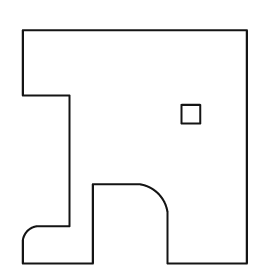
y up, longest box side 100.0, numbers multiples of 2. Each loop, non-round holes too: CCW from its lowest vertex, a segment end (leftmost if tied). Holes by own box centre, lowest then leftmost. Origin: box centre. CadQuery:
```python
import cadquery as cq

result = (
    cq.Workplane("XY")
    .moveTo(-48.0, -50.0)
    .lineTo(-18.0, -50.0)
    .lineTo(-18.0, -16.0)
    .lineTo(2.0, -16.0)
    .threePointArc((10.0, -20.0), (14.0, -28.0))
    .lineTo(14.0, -50.0)
    .lineTo(48.0, -50.0)
    .lineTo(48.0, 50.0)
    .lineTo(-48.0, 50.0)
    .lineTo(-48.0, 22.0)
    .lineTo(-28.0, 22.0)
    .lineTo(-28.0, -34.0)
    .lineTo(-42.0, -34.0)
    .threePointArc((-46.0, -36.0), (-48.0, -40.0))
    .close()
    .moveTo(20.0, 10.0)
    .lineTo(28.0, 10.0)
    .lineTo(28.0, 18.0)
    .lineTo(20.0, 18.0)
    .close()
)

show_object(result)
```